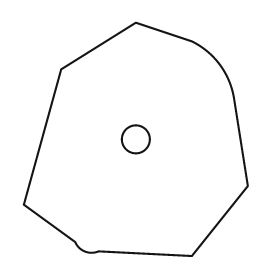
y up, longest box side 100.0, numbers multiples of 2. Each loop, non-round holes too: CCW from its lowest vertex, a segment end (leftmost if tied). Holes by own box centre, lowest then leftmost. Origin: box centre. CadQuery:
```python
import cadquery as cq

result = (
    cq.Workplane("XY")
    .moveTo(24.0, -50.0)
    .lineTo(48.0, -20.0)
    .lineTo(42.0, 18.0)
    .threePointArc((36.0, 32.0), (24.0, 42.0))
    .lineTo(0.0, 50.0)
    .lineTo(-32.0, 30.0)
    .lineTo(-48.0, -28.0)
    .lineTo(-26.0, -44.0)
    .threePointArc((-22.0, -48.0), (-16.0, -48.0))
    .close()
    .moveTo(0.0, 0.0)
    .circle(6.0)
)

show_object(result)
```